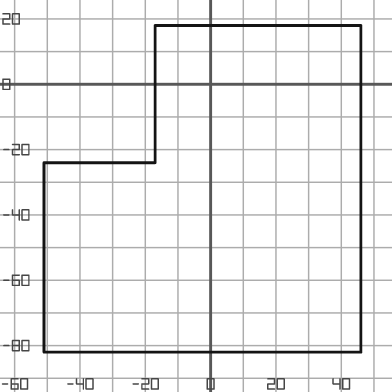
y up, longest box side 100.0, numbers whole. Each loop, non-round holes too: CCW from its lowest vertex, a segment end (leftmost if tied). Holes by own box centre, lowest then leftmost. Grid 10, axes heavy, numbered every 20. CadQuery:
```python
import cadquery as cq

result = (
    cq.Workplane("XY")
    .moveTo(-51.0, -82.0)
    .lineTo(46.0, -82.0)
    .lineTo(46.0, 18.0)
    .lineTo(-17.0, 18.0)
    .lineTo(-17.0, -24.0)
    .lineTo(-51.0, -24.0)
    .close()
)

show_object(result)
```